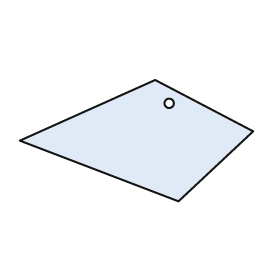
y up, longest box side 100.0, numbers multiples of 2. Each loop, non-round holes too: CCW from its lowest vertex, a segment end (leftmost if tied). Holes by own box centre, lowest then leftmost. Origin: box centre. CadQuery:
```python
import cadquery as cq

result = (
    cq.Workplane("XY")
    .moveTo(18.0, -26.0)
    .lineTo(50.0, 4.0)
    .lineTo(8.0, 26.0)
    .lineTo(-50.0, 0.0)
    .close()
    .moveTo(14.0, 16.0)
    .circle(2.0)
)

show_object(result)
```